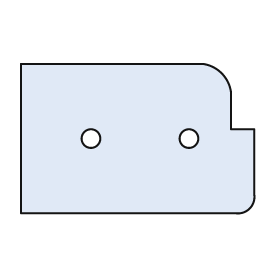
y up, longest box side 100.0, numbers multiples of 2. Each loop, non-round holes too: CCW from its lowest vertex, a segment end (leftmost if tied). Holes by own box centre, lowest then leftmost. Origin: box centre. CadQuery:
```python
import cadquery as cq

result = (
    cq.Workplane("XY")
    .moveTo(-50.0, -32.0)
    .lineTo(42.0, -32.0)
    .threePointArc((48.0, -30.0), (50.0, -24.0))
    .lineTo(50.0, 4.0)
    .lineTo(40.0, 4.0)
    .lineTo(40.0, 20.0)
    .threePointArc((36.0, 28.0), (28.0, 32.0))
    .lineTo(-50.0, 32.0)
    .close()
    .moveTo(-20.0, 0.0)
    .circle(4.0)
    .moveTo(22.0, 0.0)
    .circle(4.0)
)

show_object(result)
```